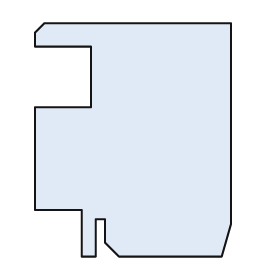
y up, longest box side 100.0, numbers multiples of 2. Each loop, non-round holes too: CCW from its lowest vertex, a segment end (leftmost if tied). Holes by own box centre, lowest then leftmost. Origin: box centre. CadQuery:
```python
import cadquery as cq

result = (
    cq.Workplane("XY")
    .moveTo(-22.0, -50.0)
    .lineTo(-16.0, -50.0)
    .lineTo(-16.0, -34.0)
    .lineTo(-12.0, -34.0)
    .lineTo(-12.0, -44.0)
    .lineTo(-6.0, -50.0)
    .lineTo(38.0, -50.0)
    .lineTo(42.0, -36.0)
    .lineTo(42.0, 50.0)
    .lineTo(-38.0, 50.0)
    .lineTo(-42.0, 46.0)
    .lineTo(-42.0, 40.0)
    .lineTo(-18.0, 40.0)
    .lineTo(-18.0, 14.0)
    .lineTo(-42.0, 14.0)
    .lineTo(-42.0, -30.0)
    .lineTo(-22.0, -30.0)
    .close()
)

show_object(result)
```